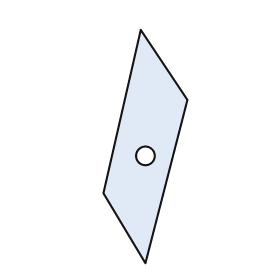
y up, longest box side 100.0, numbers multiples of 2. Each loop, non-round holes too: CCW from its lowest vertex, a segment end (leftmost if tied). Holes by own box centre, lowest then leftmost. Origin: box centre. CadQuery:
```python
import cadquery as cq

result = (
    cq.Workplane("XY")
    .moveTo(0.0, -50.0)
    .lineTo(18.0, 20.0)
    .lineTo(-2.0, 50.0)
    .lineTo(-18.0, -20.0)
    .close()
    .moveTo(0.0, -4.0)
    .circle(4.0)
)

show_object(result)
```